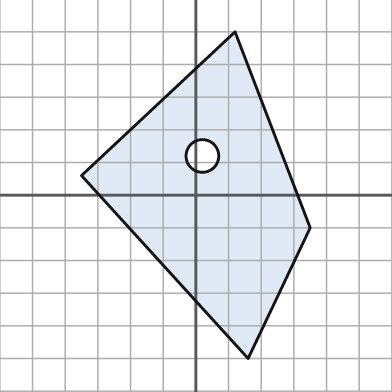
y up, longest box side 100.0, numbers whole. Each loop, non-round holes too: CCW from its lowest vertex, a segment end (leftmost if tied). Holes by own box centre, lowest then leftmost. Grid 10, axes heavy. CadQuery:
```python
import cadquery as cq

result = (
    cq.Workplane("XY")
    .moveTo(16.0, -50.0)
    .lineTo(35.0, -10.0)
    .lineTo(12.0, 50.0)
    .lineTo(-35.0, 6.0)
    .close()
    .moveTo(2.0, 12.0)
    .circle(5.0)
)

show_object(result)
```